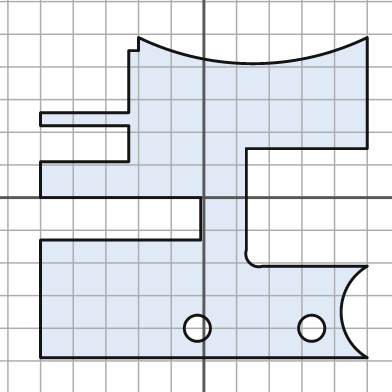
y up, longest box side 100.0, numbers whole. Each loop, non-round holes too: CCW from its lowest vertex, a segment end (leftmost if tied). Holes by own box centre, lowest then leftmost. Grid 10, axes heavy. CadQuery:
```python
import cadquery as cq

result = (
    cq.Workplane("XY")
    .moveTo(-50.0, -49.0)
    .lineTo(50.0, -49.0)
    .threePointArc((42.0, -35.0), (50.0, -21.0))
    .lineTo(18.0, -21.0)
    .threePointArc((14.0, -20.0), (13.0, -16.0))
    .lineTo(13.0, 15.0)
    .lineTo(50.0, 15.0)
    .lineTo(50.0, 49.0)
    .threePointArc((15.0, 41.0), (-20.0, 49.0))
    .lineTo(-20.0, 45.0)
    .lineTo(-23.0, 45.0)
    .lineTo(-23.0, 26.0)
    .lineTo(-50.0, 26.0)
    .lineTo(-50.0, 22.0)
    .lineTo(-23.0, 22.0)
    .lineTo(-23.0, 11.0)
    .lineTo(-50.0, 11.0)
    .lineTo(-50.0, 0.0)
    .lineTo(-1.0, 0.0)
    .lineTo(-1.0, -13.0)
    .lineTo(-50.0, -13.0)
    .close()
    .moveTo(-2.0, -40.0)
    .circle(4.0)
    .moveTo(33.0, -40.0)
    .circle(4.0)
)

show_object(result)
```